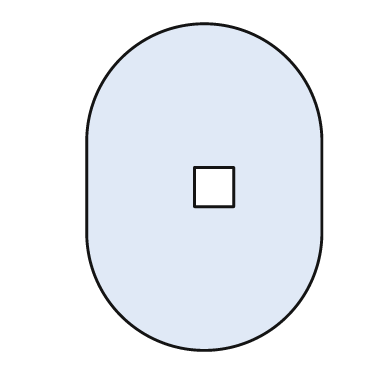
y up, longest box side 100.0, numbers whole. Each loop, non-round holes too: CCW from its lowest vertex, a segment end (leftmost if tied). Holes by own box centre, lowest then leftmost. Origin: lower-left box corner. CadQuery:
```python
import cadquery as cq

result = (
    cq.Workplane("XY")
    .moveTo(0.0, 36.0)
    .threePointArc((36.0, 0.0), (72.0, 36.0))
    .lineTo(72.0, 64.0)
    .threePointArc((36.0, 100.0), (0.0, 64.0))
    .close()
    .moveTo(33.0, 44.0)
    .lineTo(45.0, 44.0)
    .lineTo(45.0, 56.0)
    .lineTo(33.0, 56.0)
    .close()
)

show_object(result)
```